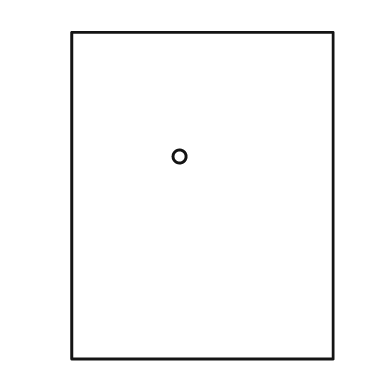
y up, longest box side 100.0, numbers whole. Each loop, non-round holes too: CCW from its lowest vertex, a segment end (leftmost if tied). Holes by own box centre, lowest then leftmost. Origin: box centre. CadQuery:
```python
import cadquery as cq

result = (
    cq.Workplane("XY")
    .moveTo(-40.0, -50.0)
    .lineTo(40.0, -50.0)
    .lineTo(40.0, 50.0)
    .lineTo(-40.0, 50.0)
    .close()
    .moveTo(-7.0, 12.0)
    .circle(2.0)
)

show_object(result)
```